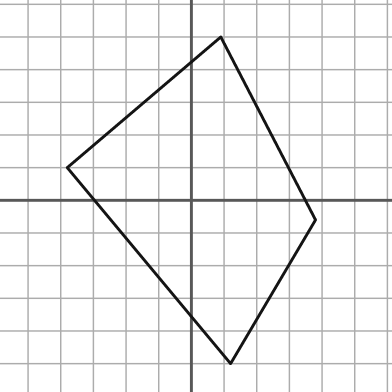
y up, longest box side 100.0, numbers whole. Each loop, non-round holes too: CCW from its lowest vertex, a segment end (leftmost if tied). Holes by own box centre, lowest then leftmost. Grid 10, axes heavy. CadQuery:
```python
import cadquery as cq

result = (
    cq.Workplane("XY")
    .moveTo(12.0, -50.0)
    .lineTo(38.0, -6.0)
    .lineTo(9.0, 50.0)
    .lineTo(-38.0, 10.0)
    .close()
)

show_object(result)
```